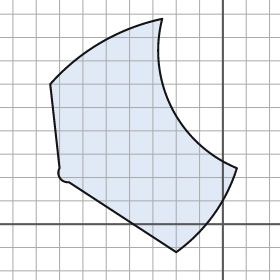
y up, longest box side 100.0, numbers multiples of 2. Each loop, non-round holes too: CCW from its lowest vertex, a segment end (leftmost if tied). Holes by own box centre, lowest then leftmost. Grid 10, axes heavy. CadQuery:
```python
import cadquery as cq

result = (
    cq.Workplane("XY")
    .moveTo(-20.0, -12.0)
    .threePointArc((-4.0, 4.0), (6.0, 24.0))
    .threePointArc((-22.0, 50.0), (-26.0, 88.0))
    .threePointArc((-52.0, 78.0), (-74.0, 60.0))
    .lineTo(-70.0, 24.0)
    .threePointArc((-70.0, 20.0), (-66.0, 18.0))
    .close()
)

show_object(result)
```